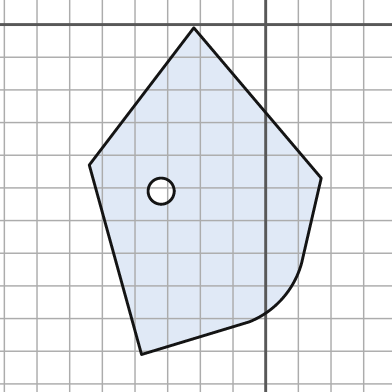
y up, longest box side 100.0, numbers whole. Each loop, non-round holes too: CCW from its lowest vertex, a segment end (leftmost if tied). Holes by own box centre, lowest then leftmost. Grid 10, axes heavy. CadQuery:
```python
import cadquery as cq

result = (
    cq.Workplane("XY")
    .moveTo(-38.0, -101.0)
    .lineTo(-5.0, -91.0)
    .threePointArc((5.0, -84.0), (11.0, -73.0))
    .lineTo(17.0, -47.0)
    .lineTo(-22.0, -1.0)
    .lineTo(-54.0, -43.0)
    .close()
    .moveTo(-32.0, -51.0)
    .circle(4.0)
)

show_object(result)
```